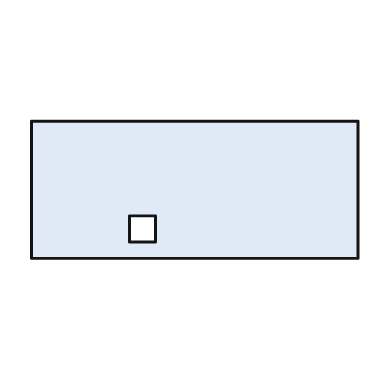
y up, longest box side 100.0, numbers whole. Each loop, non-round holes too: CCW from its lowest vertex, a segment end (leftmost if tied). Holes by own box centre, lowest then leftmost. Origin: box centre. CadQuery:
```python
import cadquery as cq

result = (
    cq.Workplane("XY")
    .moveTo(-50.0, -21.0)
    .lineTo(50.0, -21.0)
    .lineTo(50.0, 21.0)
    .lineTo(-50.0, 21.0)
    .close()
    .moveTo(-20.0, -16.0)
    .lineTo(-12.0, -16.0)
    .lineTo(-12.0, -8.0)
    .lineTo(-20.0, -8.0)
    .close()
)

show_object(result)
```